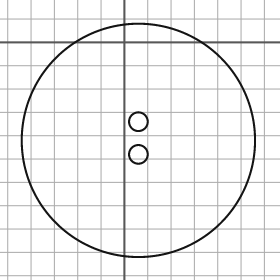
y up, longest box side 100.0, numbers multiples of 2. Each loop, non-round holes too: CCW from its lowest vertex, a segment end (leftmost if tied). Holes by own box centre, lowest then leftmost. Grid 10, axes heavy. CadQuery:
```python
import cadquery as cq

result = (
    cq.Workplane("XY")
    .moveTo(6.0, -42.0)
    .circle(50.0)
    .moveTo(6.0, -48.0)
    .circle(4.0)
    .moveTo(6.0, -34.0)
    .circle(4.0)
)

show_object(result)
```